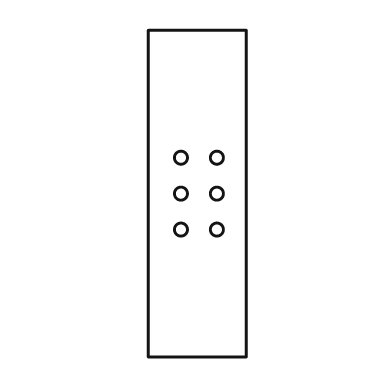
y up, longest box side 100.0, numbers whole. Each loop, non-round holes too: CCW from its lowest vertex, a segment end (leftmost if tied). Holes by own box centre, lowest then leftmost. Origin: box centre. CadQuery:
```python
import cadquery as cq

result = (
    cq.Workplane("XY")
    .moveTo(-15.0, -50.0)
    .lineTo(15.0, -50.0)
    .lineTo(15.0, 50.0)
    .lineTo(-15.0, 50.0)
    .close()
    .moveTo(-5.0, -11.0)
    .circle(2.0)
    .moveTo(6.0, -11.0)
    .circle(2.0)
    .moveTo(-5.0, 0.0)
    .circle(2.0)
    .moveTo(6.0, 0.0)
    .circle(2.0)
    .moveTo(-5.0, 11.0)
    .circle(2.0)
    .moveTo(6.0, 11.0)
    .circle(2.0)
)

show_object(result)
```